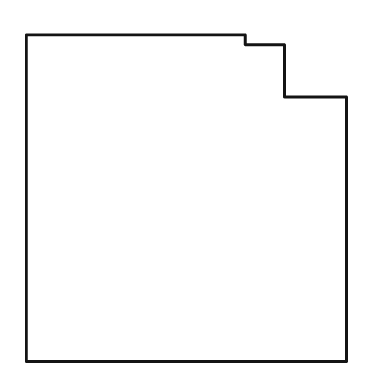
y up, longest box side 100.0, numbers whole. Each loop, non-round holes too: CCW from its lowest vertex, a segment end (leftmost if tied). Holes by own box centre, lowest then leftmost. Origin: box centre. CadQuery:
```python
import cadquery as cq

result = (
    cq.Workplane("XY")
    .moveTo(-49.0, -50.0)
    .lineTo(49.0, -50.0)
    .lineTo(49.0, 31.0)
    .lineTo(30.0, 31.0)
    .lineTo(30.0, 47.0)
    .lineTo(18.0, 47.0)
    .lineTo(18.0, 50.0)
    .lineTo(-49.0, 50.0)
    .close()
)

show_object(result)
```